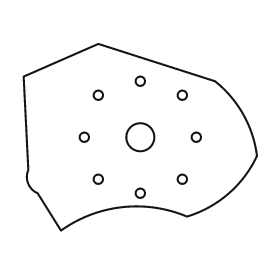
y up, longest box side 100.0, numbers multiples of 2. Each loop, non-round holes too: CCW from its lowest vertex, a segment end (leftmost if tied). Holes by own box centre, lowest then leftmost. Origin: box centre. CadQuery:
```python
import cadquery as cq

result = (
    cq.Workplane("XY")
    .moveTo(-34.0, -40.0)
    .threePointArc((-8.0, -30.0), (20.0, -34.0))
    .threePointArc((38.0, -24.0), (50.0, -8.0))
    .threePointArc((44.0, 10.0), (32.0, 24.0))
    .lineTo(-18.0, 40.0)
    .lineTo(-50.0, 26.0)
    .lineTo(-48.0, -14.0)
    .threePointArc((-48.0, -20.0), (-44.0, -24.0))
    .close()
    .moveTo(0.0, -24.0)
    .circle(2.0)
    .moveTo(-18.0, -18.0)
    .circle(2.0)
    .moveTo(18.0, -18.0)
    .circle(2.0)
    .moveTo(-24.0, 0.0)
    .circle(2.0)
    .moveTo(0.0, 0.0)
    .circle(6.0)
    .moveTo(24.0, 0.0)
    .circle(2.0)
    .moveTo(-18.0, 18.0)
    .circle(2.0)
    .moveTo(18.0, 18.0)
    .circle(2.0)
    .moveTo(0.0, 24.0)
    .circle(2.0)
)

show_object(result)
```